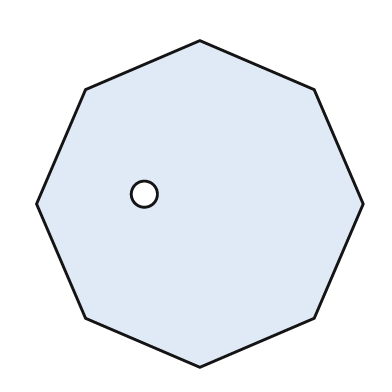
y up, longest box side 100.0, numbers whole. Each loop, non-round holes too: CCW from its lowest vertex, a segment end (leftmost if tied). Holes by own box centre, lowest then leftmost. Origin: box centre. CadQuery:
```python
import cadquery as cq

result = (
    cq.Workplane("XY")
    .moveTo(0.0, -50.0)
    .lineTo(35.0, -35.0)
    .lineTo(50.0, 0.0)
    .lineTo(35.0, 35.0)
    .lineTo(0.0, 50.0)
    .lineTo(-35.0, 35.0)
    .lineTo(-50.0, 0.0)
    .lineTo(-35.0, -35.0)
    .close()
    .moveTo(-17.0, 3.0)
    .circle(4.0)
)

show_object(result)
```